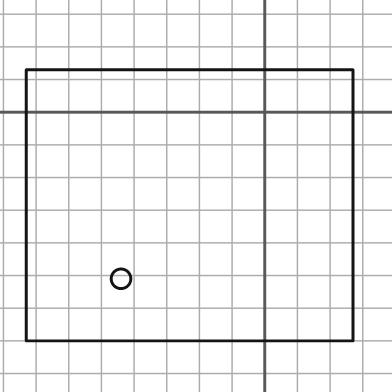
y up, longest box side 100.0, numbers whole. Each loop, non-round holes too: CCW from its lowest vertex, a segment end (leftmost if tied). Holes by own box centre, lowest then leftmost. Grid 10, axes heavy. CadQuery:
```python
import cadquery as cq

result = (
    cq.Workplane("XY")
    .moveTo(-73.0, -70.0)
    .lineTo(27.0, -70.0)
    .lineTo(27.0, 13.0)
    .lineTo(-73.0, 13.0)
    .close()
    .moveTo(-44.0, -51.0)
    .circle(3.0)
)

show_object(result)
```